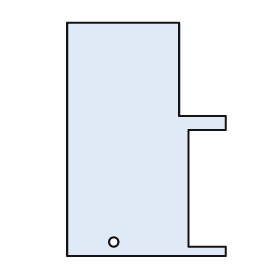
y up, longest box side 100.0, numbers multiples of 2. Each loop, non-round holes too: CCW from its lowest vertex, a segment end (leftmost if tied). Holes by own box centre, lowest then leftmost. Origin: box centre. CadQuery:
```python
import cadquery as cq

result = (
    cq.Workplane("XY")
    .moveTo(-34.0, -50.0)
    .lineTo(34.0, -50.0)
    .lineTo(34.0, -46.0)
    .lineTo(18.0, -46.0)
    .lineTo(18.0, 4.0)
    .lineTo(34.0, 4.0)
    .lineTo(34.0, 10.0)
    .lineTo(14.0, 10.0)
    .lineTo(14.0, 50.0)
    .lineTo(-34.0, 50.0)
    .close()
    .moveTo(-14.0, -44.0)
    .circle(2.0)
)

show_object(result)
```